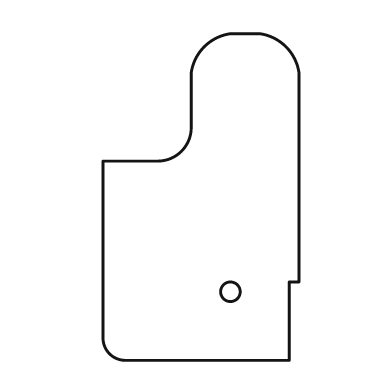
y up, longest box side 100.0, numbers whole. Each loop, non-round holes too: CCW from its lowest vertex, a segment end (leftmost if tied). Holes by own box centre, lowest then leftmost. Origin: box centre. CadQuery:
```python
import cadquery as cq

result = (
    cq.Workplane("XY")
    .moveTo(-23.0, -50.0)
    .lineTo(27.0, -50.0)
    .lineTo(27.0, -26.0)
    .lineTo(30.0, -26.0)
    .lineTo(30.0, 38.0)
    .threePointArc((26.0, 46.0), (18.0, 50.0))
    .lineTo(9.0, 50.0)
    .threePointArc((1.0, 46.0), (-3.0, 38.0))
    .lineTo(-3.0, 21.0)
    .threePointArc((-6.0, 14.0), (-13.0, 11.0))
    .lineTo(-30.0, 11.0)
    .lineTo(-30.0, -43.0)
    .threePointArc((-28.0, -48.0), (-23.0, -50.0))
    .close()
    .moveTo(9.0, -29.0)
    .circle(3.0)
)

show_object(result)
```